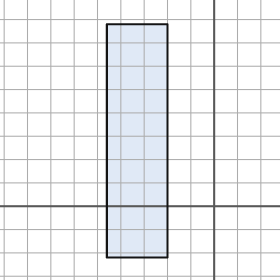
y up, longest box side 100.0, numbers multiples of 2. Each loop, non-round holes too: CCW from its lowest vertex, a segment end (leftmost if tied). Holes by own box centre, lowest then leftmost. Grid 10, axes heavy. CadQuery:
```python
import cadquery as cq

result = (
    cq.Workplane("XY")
    .moveTo(-46.0, -22.0)
    .lineTo(-20.0, -22.0)
    .lineTo(-20.0, 78.0)
    .lineTo(-46.0, 78.0)
    .close()
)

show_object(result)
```